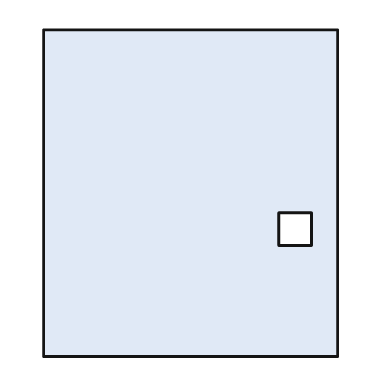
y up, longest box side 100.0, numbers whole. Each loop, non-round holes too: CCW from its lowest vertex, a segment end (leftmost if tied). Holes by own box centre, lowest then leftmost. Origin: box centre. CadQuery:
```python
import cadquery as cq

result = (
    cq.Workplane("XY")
    .moveTo(-45.0, -50.0)
    .lineTo(45.0, -50.0)
    .lineTo(45.0, 50.0)
    .lineTo(-45.0, 50.0)
    .close()
    .moveTo(27.0, -16.0)
    .lineTo(37.0, -16.0)
    .lineTo(37.0, -6.0)
    .lineTo(27.0, -6.0)
    .close()
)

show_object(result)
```